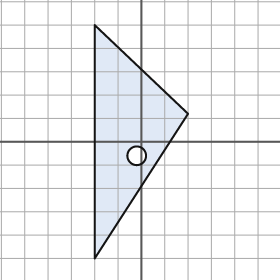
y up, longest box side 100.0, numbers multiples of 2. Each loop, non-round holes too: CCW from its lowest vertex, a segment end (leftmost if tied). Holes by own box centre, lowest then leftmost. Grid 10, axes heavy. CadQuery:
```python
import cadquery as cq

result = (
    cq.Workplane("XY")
    .moveTo(-20.0, -50.0)
    .lineTo(20.0, 12.0)
    .lineTo(-20.0, 50.0)
    .close()
    .moveTo(-2.0, -6.0)
    .circle(4.0)
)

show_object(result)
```